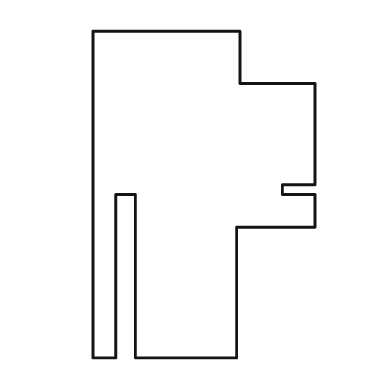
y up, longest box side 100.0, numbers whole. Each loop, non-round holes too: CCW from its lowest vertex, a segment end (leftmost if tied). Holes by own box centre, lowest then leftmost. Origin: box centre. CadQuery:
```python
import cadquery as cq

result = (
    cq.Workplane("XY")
    .moveTo(-34.0, -50.0)
    .lineTo(-27.0, -50.0)
    .lineTo(-27.0, 0.0)
    .lineTo(-21.0, 0.0)
    .lineTo(-21.0, -50.0)
    .lineTo(10.0, -50.0)
    .lineTo(10.0, -10.0)
    .lineTo(34.0, -10.0)
    .lineTo(34.0, 0.0)
    .lineTo(24.0, 0.0)
    .lineTo(24.0, 3.0)
    .lineTo(34.0, 3.0)
    .lineTo(34.0, 34.0)
    .lineTo(11.0, 34.0)
    .lineTo(11.0, 50.0)
    .lineTo(-34.0, 50.0)
    .close()
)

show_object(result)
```